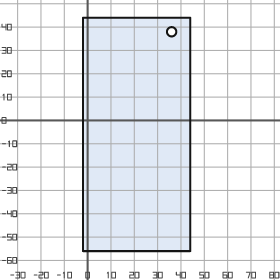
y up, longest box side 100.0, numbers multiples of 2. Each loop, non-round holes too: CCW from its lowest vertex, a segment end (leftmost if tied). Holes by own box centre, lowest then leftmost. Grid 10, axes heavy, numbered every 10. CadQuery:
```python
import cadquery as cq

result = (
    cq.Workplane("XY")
    .moveTo(-2.0, -56.0)
    .lineTo(44.0, -56.0)
    .lineTo(44.0, 44.0)
    .lineTo(-2.0, 44.0)
    .close()
    .moveTo(36.0, 38.0)
    .circle(2.0)
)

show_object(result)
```